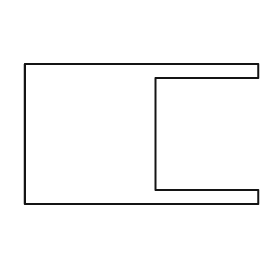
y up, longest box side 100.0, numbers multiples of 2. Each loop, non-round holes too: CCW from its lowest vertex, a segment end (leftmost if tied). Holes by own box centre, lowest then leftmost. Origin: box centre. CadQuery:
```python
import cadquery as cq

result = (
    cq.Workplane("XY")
    .moveTo(-50.0, -30.0)
    .lineTo(50.0, -30.0)
    .lineTo(50.0, -24.0)
    .lineTo(6.0, -24.0)
    .lineTo(6.0, 24.0)
    .lineTo(50.0, 24.0)
    .lineTo(50.0, 30.0)
    .lineTo(-50.0, 30.0)
    .close()
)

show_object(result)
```